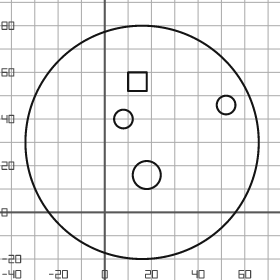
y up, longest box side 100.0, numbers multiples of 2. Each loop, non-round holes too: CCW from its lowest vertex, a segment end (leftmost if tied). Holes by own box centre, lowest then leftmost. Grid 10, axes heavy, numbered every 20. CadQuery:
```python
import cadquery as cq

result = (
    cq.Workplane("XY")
    .moveTo(16.0, 30.0)
    .circle(50.0)
    .moveTo(18.0, 16.0)
    .circle(6.0)
    .moveTo(8.0, 40.0)
    .circle(4.0)
    .moveTo(52.0, 46.0)
    .circle(4.0)
    .moveTo(10.0, 52.0)
    .lineTo(18.0, 52.0)
    .lineTo(18.0, 60.0)
    .lineTo(10.0, 60.0)
    .close()
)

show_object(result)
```